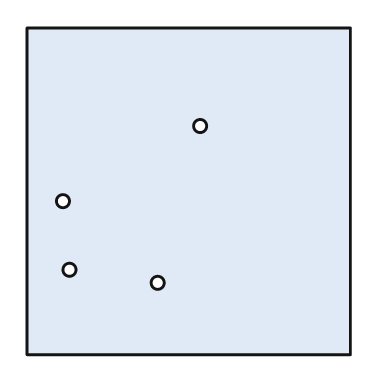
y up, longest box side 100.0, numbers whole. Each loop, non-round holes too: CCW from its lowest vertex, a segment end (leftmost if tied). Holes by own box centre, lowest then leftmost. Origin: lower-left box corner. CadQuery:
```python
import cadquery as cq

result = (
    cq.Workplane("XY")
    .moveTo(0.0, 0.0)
    .lineTo(99.0, 0.0)
    .lineTo(99.0, 100.0)
    .lineTo(0.0, 100.0)
    .close()
    .moveTo(40.0, 22.0)
    .circle(2.0)
    .moveTo(13.0, 26.0)
    .circle(2.0)
    .moveTo(11.0, 47.0)
    .circle(2.0)
    .moveTo(53.0, 70.0)
    .circle(2.0)
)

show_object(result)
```